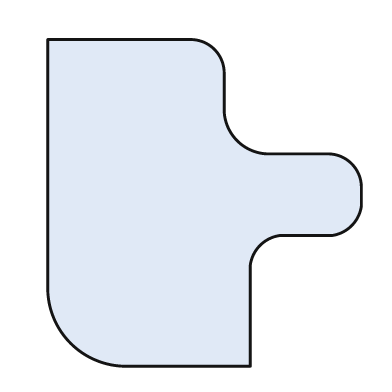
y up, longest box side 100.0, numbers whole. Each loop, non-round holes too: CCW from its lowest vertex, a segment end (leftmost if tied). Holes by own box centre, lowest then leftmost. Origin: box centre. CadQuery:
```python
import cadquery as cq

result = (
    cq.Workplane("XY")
    .moveTo(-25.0, -50.0)
    .lineTo(14.0, -50.0)
    .lineTo(14.0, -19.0)
    .threePointArc((17.0, -13.0), (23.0, -10.0))
    .lineTo(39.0, -10.0)
    .threePointArc((45.0, -7.0), (48.0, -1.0))
    .lineTo(48.0, 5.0)
    .threePointArc((45.0, 12.0), (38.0, 15.0))
    .lineTo(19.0, 15.0)
    .threePointArc((10.0, 19.0), (6.0, 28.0))
    .lineTo(6.0, 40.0)
    .threePointArc((3.0, 47.0), (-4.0, 50.0))
    .lineTo(-48.0, 50.0)
    .lineTo(-48.0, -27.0)
    .threePointArc((-41.0, -43.0), (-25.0, -50.0))
    .close()
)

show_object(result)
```